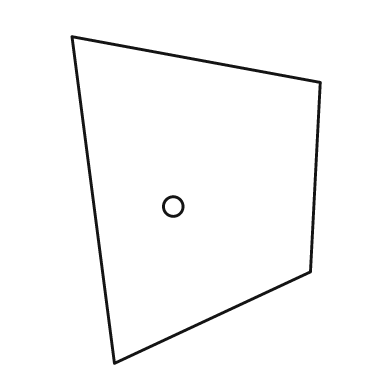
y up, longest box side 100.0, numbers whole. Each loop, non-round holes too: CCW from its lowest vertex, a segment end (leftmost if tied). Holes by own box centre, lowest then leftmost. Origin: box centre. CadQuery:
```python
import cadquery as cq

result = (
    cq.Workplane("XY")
    .moveTo(-25.0, -50.0)
    .lineTo(35.0, -22.0)
    .lineTo(38.0, 36.0)
    .lineTo(-38.0, 50.0)
    .close()
    .moveTo(-7.0, -2.0)
    .circle(3.0)
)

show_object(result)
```